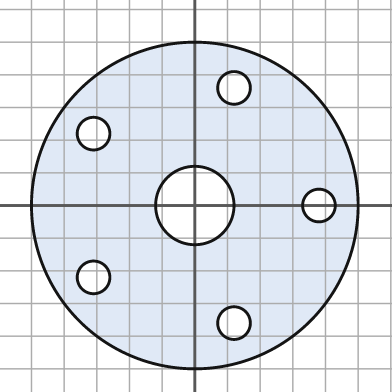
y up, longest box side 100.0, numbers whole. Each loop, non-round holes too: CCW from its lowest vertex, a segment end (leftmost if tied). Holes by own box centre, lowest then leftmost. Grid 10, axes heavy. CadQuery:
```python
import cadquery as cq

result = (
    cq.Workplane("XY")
    .moveTo(0.0, 0.0)
    .circle(50.0)
    .moveTo(12.0, -36.0)
    .circle(5.0)
    .moveTo(-31.0, -22.0)
    .circle(5.0)
    .moveTo(0.0, 0.0)
    .circle(12.0)
    .moveTo(38.0, 0.0)
    .circle(5.0)
    .moveTo(-31.0, 22.0)
    .circle(5.0)
    .moveTo(12.0, 36.0)
    .circle(5.0)
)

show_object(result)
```